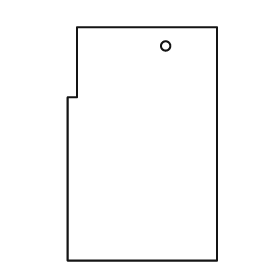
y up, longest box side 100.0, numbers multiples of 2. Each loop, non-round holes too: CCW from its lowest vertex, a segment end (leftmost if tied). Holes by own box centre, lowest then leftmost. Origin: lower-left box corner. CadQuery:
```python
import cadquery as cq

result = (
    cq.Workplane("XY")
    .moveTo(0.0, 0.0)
    .lineTo(64.0, 0.0)
    .lineTo(64.0, 100.0)
    .lineTo(4.0, 100.0)
    .lineTo(4.0, 70.0)
    .lineTo(0.0, 70.0)
    .close()
    .moveTo(42.0, 92.0)
    .circle(2.0)
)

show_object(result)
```